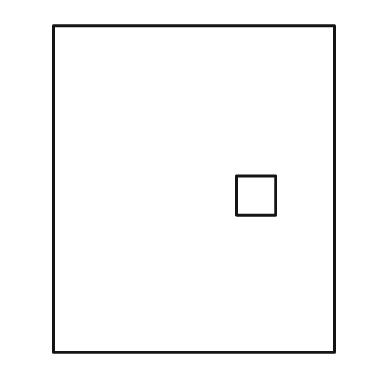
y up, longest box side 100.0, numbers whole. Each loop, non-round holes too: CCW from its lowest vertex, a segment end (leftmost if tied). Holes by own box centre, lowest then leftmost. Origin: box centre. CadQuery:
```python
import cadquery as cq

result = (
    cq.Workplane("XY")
    .moveTo(-43.0, -50.0)
    .lineTo(43.0, -50.0)
    .lineTo(43.0, 50.0)
    .lineTo(-43.0, 50.0)
    .close()
    .moveTo(13.0, -8.0)
    .lineTo(25.0, -8.0)
    .lineTo(25.0, 4.0)
    .lineTo(13.0, 4.0)
    .close()
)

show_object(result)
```